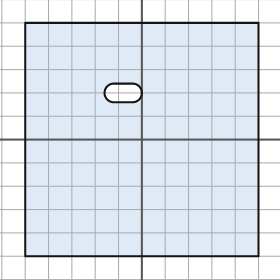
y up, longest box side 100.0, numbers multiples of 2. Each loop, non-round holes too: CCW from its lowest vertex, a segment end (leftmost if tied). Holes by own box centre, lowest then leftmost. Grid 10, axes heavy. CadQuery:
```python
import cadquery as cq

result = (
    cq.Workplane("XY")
    .moveTo(-50.0, -50.0)
    .lineTo(50.0, -50.0)
    .lineTo(50.0, 50.0)
    .lineTo(-50.0, 50.0)
    .close()
    .moveTo(-12.0, 16.0)
    .lineTo(-4.0, 16.0)
    .threePointArc((0.0, 20.0), (-4.0, 24.0))
    .lineTo(-12.0, 24.0)
    .threePointArc((-16.0, 20.0), (-12.0, 16.0))
    .close()
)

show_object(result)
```